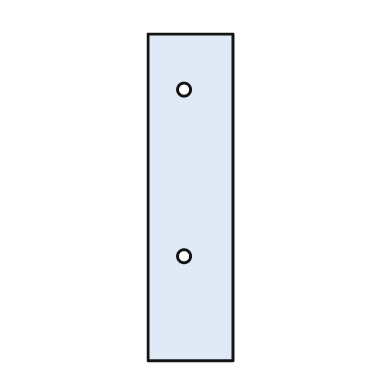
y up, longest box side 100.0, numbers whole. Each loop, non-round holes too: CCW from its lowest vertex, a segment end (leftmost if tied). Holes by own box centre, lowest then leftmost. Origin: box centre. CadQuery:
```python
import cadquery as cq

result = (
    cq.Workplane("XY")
    .moveTo(-13.0, -50.0)
    .lineTo(13.0, -50.0)
    .lineTo(13.0, 50.0)
    .lineTo(-13.0, 50.0)
    .close()
    .moveTo(-2.0, -18.0)
    .circle(2.0)
    .moveTo(-2.0, 33.0)
    .circle(2.0)
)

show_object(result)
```